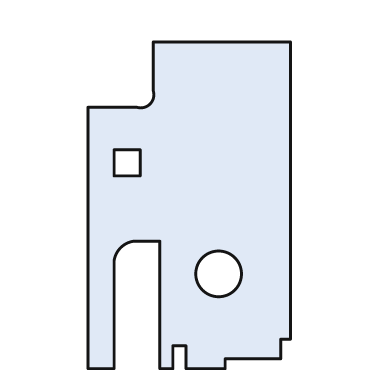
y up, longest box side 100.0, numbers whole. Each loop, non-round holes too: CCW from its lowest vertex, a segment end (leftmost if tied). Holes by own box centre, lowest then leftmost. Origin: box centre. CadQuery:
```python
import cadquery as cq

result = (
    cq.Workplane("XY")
    .moveTo(-31.0, -50.0)
    .lineTo(-23.0, -50.0)
    .lineTo(-23.0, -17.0)
    .threePointArc((-21.0, -13.0), (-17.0, -11.0))
    .lineTo(-9.0, -11.0)
    .lineTo(-9.0, -50.0)
    .lineTo(-5.0, -50.0)
    .lineTo(-5.0, -43.0)
    .lineTo(-1.0, -43.0)
    .lineTo(-1.0, -50.0)
    .lineTo(11.0, -50.0)
    .lineTo(11.0, -47.0)
    .lineTo(28.0, -47.0)
    .lineTo(28.0, -41.0)
    .lineTo(31.0, -41.0)
    .lineTo(31.0, 50.0)
    .lineTo(-11.0, 50.0)
    .lineTo(-11.0, 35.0)
    .threePointArc((-12.0, 31.0), (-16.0, 30.0))
    .lineTo(-31.0, 30.0)
    .close()
    .moveTo(9.0, -21.0)
    .circle(7.0)
    .moveTo(-23.0, 9.0)
    .lineTo(-15.0, 9.0)
    .lineTo(-15.0, 17.0)
    .lineTo(-23.0, 17.0)
    .close()
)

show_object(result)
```